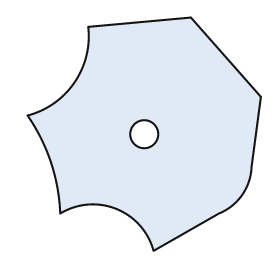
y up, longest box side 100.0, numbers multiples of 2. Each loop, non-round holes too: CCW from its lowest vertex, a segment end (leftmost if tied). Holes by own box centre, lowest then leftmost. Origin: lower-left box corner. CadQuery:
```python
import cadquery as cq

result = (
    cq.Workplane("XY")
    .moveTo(54.0, 0.0)
    .lineTo(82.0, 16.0)
    .threePointArc((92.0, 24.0), (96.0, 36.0))
    .lineTo(100.0, 66.0)
    .lineTo(70.0, 100.0)
    .lineTo(26.0, 96.0)
    .threePointArc((20.0, 72.0), (0.0, 58.0))
    .threePointArc((10.0, 38.0), (14.0, 16.0))
    .threePointArc((38.0, 18.0), (54.0, 0.0))
    .close()
    .moveTo(50.0, 50.0)
    .circle(6.0)
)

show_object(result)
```